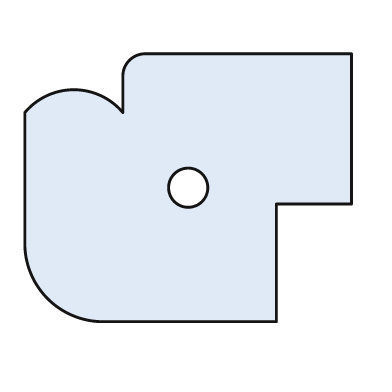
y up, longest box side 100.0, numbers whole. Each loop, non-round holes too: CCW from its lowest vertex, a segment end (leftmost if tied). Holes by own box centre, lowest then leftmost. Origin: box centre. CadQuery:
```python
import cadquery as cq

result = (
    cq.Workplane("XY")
    .moveTo(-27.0, -41.0)
    .lineTo(27.0, -41.0)
    .lineTo(27.0, -5.0)
    .lineTo(50.0, -5.0)
    .lineTo(50.0, 41.0)
    .lineTo(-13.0, 41.0)
    .threePointArc((-18.0, 39.0), (-20.0, 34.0))
    .lineTo(-20.0, 23.0)
    .threePointArc((-35.0, 30.0), (-50.0, 23.0))
    .lineTo(-50.0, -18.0)
    .threePointArc((-43.0, -34.0), (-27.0, -41.0))
    .close()
    .moveTo(0.0, 0.0)
    .circle(6.0)
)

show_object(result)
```